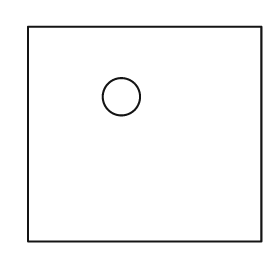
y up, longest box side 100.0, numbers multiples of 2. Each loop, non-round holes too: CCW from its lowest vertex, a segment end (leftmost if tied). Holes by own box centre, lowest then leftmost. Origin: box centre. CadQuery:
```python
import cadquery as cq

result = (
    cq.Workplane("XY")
    .moveTo(-50.0, -46.0)
    .lineTo(50.0, -46.0)
    .lineTo(50.0, 46.0)
    .lineTo(-50.0, 46.0)
    .close()
    .moveTo(-10.0, 16.0)
    .circle(8.0)
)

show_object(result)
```